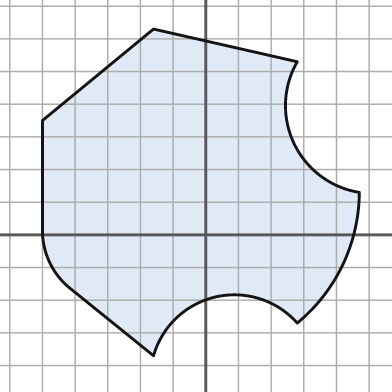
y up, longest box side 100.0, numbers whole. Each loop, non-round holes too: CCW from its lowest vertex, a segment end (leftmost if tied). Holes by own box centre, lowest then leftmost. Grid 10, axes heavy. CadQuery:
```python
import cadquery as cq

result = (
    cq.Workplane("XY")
    .moveTo(-16.0, -37.0)
    .threePointArc((3.0, -19.0), (28.0, -27.0))
    .threePointArc((42.0, -9.0), (47.0, 13.0))
    .threePointArc((27.0, 28.0), (28.0, 53.0))
    .lineTo(-16.0, 63.0)
    .lineTo(-50.0, 35.0)
    .lineTo(-50.0, 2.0)
    .threePointArc((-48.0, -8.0), (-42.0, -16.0))
    .close()
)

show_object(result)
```